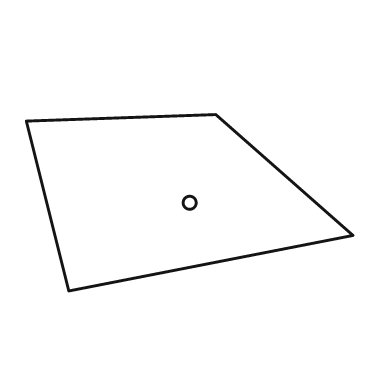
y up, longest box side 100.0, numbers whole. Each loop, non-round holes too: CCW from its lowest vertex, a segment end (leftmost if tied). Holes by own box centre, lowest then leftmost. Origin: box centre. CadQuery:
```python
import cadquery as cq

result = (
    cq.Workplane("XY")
    .moveTo(-37.0, -27.0)
    .lineTo(50.0, -10.0)
    .lineTo(8.0, 27.0)
    .lineTo(-50.0, 25.0)
    .close()
    .moveTo(0.0, 0.0)
    .circle(2.0)
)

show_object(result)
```